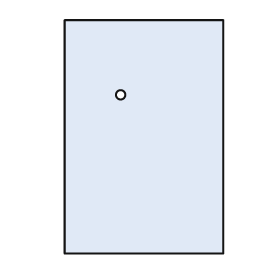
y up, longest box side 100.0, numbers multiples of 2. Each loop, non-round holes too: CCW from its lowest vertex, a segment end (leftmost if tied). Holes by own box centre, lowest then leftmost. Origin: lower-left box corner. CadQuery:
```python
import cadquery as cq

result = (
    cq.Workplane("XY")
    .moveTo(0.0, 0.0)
    .lineTo(68.0, 0.0)
    .lineTo(68.0, 100.0)
    .lineTo(0.0, 100.0)
    .close()
    .moveTo(24.0, 68.0)
    .circle(2.0)
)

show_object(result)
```